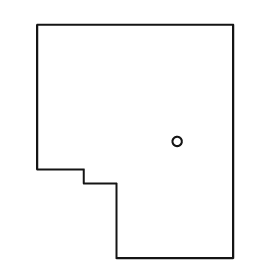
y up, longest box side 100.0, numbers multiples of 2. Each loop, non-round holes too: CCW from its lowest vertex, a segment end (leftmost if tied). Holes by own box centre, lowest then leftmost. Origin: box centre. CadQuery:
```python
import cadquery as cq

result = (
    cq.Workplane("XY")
    .moveTo(-8.0, -50.0)
    .lineTo(42.0, -50.0)
    .lineTo(42.0, 50.0)
    .lineTo(-42.0, 50.0)
    .lineTo(-42.0, -12.0)
    .lineTo(-22.0, -12.0)
    .lineTo(-22.0, -18.0)
    .lineTo(-8.0, -18.0)
    .close()
    .moveTo(18.0, 0.0)
    .circle(2.0)
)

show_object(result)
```